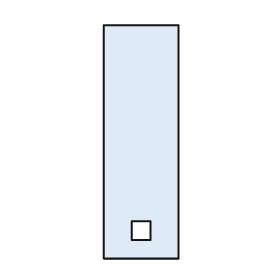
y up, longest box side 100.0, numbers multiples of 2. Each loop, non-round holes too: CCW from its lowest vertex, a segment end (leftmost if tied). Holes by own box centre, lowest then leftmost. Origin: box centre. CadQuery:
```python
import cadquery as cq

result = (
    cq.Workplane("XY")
    .moveTo(-16.0, -50.0)
    .lineTo(16.0, -50.0)
    .lineTo(16.0, 50.0)
    .lineTo(-16.0, 50.0)
    .close()
    .moveTo(-4.0, -42.0)
    .lineTo(4.0, -42.0)
    .lineTo(4.0, -34.0)
    .lineTo(-4.0, -34.0)
    .close()
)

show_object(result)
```